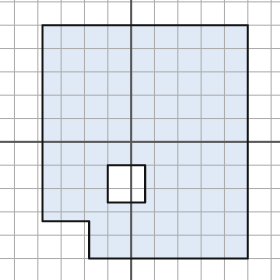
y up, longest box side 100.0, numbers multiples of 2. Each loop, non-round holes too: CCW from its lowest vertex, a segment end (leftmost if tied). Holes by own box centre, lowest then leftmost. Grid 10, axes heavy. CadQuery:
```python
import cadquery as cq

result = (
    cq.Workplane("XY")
    .moveTo(-18.0, -50.0)
    .lineTo(50.0, -50.0)
    .lineTo(50.0, 50.0)
    .lineTo(-38.0, 50.0)
    .lineTo(-38.0, -34.0)
    .lineTo(-18.0, -34.0)
    .close()
    .moveTo(-10.0, -26.0)
    .lineTo(6.0, -26.0)
    .lineTo(6.0, -10.0)
    .lineTo(-10.0, -10.0)
    .close()
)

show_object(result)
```